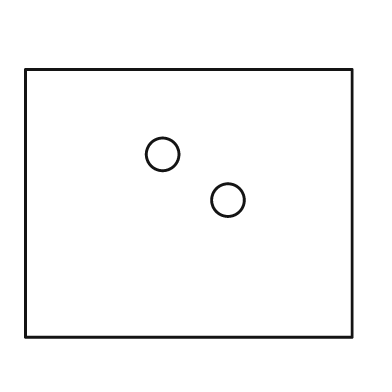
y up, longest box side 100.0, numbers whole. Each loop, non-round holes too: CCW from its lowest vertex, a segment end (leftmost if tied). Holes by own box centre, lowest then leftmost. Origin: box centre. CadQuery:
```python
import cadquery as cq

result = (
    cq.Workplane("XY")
    .moveTo(-50.0, -41.0)
    .lineTo(50.0, -41.0)
    .lineTo(50.0, 41.0)
    .lineTo(-50.0, 41.0)
    .close()
    .moveTo(12.0, 1.0)
    .circle(5.0)
    .moveTo(-8.0, 15.0)
    .circle(5.0)
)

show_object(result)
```